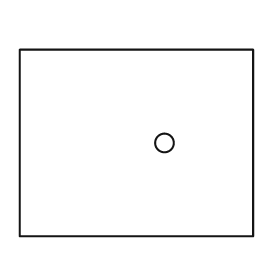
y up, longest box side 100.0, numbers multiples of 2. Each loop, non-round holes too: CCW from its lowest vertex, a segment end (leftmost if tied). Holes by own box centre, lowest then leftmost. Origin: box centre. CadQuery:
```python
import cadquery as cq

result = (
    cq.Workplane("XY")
    .moveTo(-50.0, -40.0)
    .lineTo(50.0, -40.0)
    .lineTo(50.0, 40.0)
    .lineTo(-50.0, 40.0)
    .close()
    .moveTo(12.0, 0.0)
    .circle(4.0)
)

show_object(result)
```